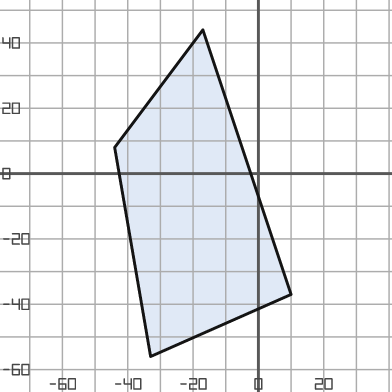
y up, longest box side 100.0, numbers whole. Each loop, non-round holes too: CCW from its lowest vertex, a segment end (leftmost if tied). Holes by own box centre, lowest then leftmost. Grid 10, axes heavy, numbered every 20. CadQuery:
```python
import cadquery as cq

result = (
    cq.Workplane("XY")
    .moveTo(-33.0, -56.0)
    .lineTo(10.0, -37.0)
    .lineTo(-17.0, 44.0)
    .lineTo(-44.0, 8.0)
    .close()
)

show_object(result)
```